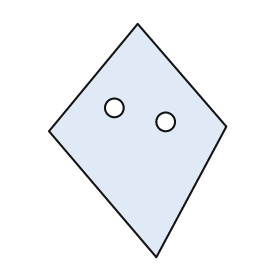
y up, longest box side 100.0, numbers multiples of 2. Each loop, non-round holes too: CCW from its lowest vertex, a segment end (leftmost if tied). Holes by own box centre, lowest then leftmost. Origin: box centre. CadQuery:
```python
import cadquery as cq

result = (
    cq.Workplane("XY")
    .moveTo(8.0, -50.0)
    .lineTo(38.0, 6.0)
    .lineTo(0.0, 50.0)
    .lineTo(-38.0, 4.0)
    .close()
    .moveTo(12.0, 8.0)
    .circle(4.0)
    .moveTo(-10.0, 14.0)
    .circle(4.0)
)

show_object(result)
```